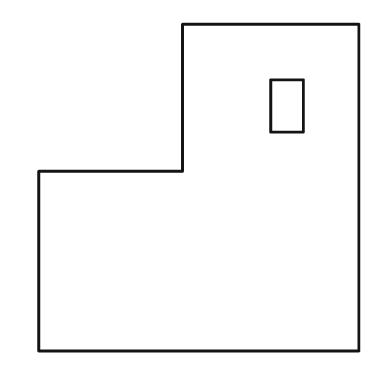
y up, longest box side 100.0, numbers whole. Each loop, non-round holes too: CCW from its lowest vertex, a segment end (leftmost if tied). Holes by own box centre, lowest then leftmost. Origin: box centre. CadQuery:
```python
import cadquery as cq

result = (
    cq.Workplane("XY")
    .moveTo(-49.0, -50.0)
    .lineTo(49.0, -50.0)
    .lineTo(49.0, 50.0)
    .lineTo(-5.0, 50.0)
    .lineTo(-5.0, 5.0)
    .lineTo(-49.0, 5.0)
    .close()
    .moveTo(22.0, 17.0)
    .lineTo(32.0, 17.0)
    .lineTo(32.0, 33.0)
    .lineTo(22.0, 33.0)
    .close()
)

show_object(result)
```